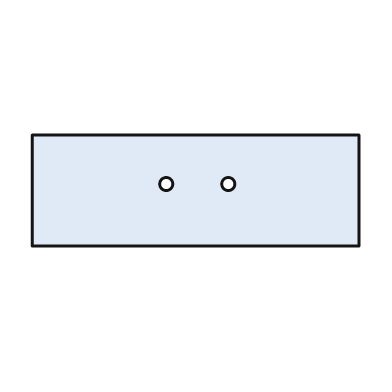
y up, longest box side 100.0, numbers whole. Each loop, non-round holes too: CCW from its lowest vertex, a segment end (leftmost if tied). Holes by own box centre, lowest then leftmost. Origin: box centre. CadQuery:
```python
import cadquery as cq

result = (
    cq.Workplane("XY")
    .moveTo(-50.0, -17.0)
    .lineTo(50.0, -17.0)
    .lineTo(50.0, 17.0)
    .lineTo(-50.0, 17.0)
    .close()
    .moveTo(-9.0, 2.0)
    .circle(2.0)
    .moveTo(10.0, 2.0)
    .circle(2.0)
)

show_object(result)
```